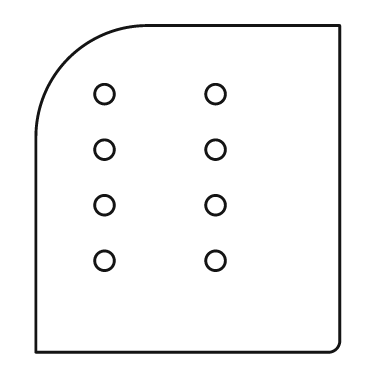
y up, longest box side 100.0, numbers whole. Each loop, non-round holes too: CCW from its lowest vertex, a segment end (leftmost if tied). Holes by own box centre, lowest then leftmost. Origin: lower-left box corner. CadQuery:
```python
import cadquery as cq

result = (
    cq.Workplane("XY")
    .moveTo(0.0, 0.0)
    .lineTo(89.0, 0.0)
    .threePointArc((92.0, 1.0), (93.0, 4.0))
    .lineTo(93.0, 100.0)
    .lineTo(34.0, 100.0)
    .threePointArc((10.0, 90.0), (0.0, 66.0))
    .close()
    .moveTo(21.0, 28.0)
    .circle(3.0)
    .moveTo(55.0, 28.0)
    .circle(3.0)
    .moveTo(21.0, 45.0)
    .circle(3.0)
    .moveTo(55.0, 45.0)
    .circle(3.0)
    .moveTo(21.0, 62.0)
    .circle(3.0)
    .moveTo(55.0, 62.0)
    .circle(3.0)
    .moveTo(21.0, 79.0)
    .circle(3.0)
    .moveTo(55.0, 79.0)
    .circle(3.0)
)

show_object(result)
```